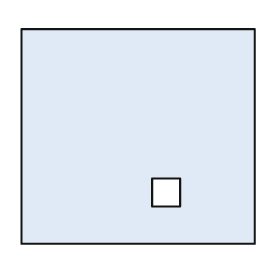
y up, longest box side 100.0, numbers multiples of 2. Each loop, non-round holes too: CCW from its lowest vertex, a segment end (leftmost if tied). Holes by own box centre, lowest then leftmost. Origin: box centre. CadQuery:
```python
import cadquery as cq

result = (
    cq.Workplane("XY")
    .moveTo(-50.0, -46.0)
    .lineTo(50.0, -46.0)
    .lineTo(50.0, 46.0)
    .lineTo(-50.0, 46.0)
    .close()
    .moveTo(6.0, -30.0)
    .lineTo(18.0, -30.0)
    .lineTo(18.0, -18.0)
    .lineTo(6.0, -18.0)
    .close()
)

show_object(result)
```